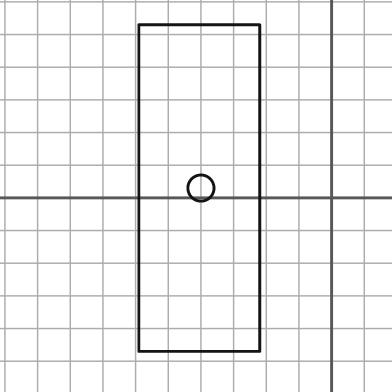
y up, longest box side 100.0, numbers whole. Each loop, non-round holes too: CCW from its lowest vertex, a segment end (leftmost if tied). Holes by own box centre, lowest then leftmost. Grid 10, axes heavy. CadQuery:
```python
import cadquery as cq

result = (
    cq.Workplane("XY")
    .moveTo(-59.0, -47.0)
    .lineTo(-22.0, -47.0)
    .lineTo(-22.0, 53.0)
    .lineTo(-59.0, 53.0)
    .close()
    .moveTo(-40.0, 3.0)
    .circle(4.0)
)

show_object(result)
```